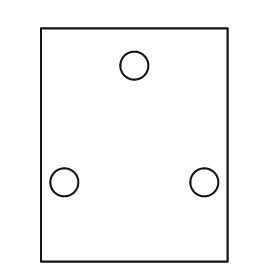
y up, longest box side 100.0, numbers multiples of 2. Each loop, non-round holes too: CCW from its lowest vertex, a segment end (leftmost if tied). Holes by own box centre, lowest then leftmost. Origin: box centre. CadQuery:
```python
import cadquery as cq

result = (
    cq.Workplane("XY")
    .moveTo(-40.0, -50.0)
    .lineTo(40.0, -50.0)
    .lineTo(40.0, 50.0)
    .lineTo(-40.0, 50.0)
    .close()
    .moveTo(-30.0, -16.0)
    .circle(6.0)
    .moveTo(30.0, -16.0)
    .circle(6.0)
    .moveTo(0.0, 34.0)
    .circle(6.0)
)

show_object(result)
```